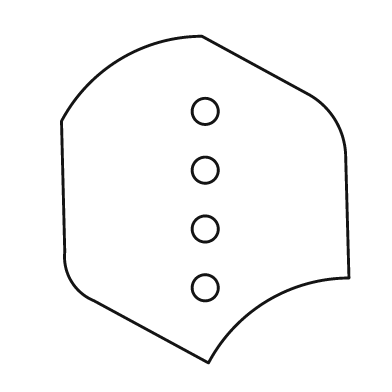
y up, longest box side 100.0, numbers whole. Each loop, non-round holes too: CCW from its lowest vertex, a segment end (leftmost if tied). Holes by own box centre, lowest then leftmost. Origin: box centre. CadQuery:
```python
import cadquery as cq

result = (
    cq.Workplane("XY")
    .moveTo(1.0, -50.0)
    .threePointArc((19.0, -31.0), (44.0, -24.0))
    .lineTo(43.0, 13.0)
    .threePointArc((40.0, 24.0), (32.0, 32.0))
    .lineTo(-1.0, 50.0)
    .threePointArc((-26.0, 43.0), (-44.0, 24.0))
    .lineTo(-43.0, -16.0)
    .threePointArc((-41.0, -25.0), (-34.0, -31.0))
    .close()
    .moveTo(0.0, -27.0)
    .circle(4.0)
    .moveTo(0.0, -9.0)
    .circle(4.0)
    .moveTo(0.0, 9.0)
    .circle(4.0)
    .moveTo(0.0, 27.0)
    .circle(4.0)
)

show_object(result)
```